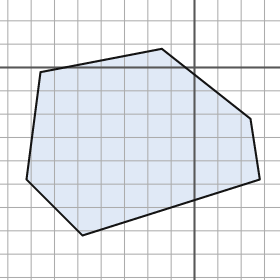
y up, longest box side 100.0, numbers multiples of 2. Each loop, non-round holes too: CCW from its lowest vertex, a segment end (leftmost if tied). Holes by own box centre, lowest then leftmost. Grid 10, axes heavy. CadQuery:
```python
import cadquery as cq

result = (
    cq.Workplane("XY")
    .moveTo(-48.0, -72.0)
    .lineTo(28.0, -48.0)
    .lineTo(24.0, -22.0)
    .lineTo(-14.0, 8.0)
    .lineTo(-66.0, -2.0)
    .lineTo(-72.0, -48.0)
    .close()
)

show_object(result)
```